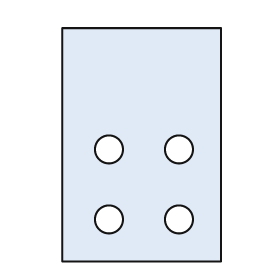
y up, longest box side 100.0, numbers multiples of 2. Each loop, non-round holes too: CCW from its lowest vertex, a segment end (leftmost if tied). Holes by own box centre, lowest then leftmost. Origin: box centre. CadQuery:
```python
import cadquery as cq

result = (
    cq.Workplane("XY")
    .moveTo(-34.0, -50.0)
    .lineTo(34.0, -50.0)
    .lineTo(34.0, 50.0)
    .lineTo(-34.0, 50.0)
    .close()
    .moveTo(-14.0, -32.0)
    .circle(6.0)
    .moveTo(16.0, -32.0)
    .circle(6.0)
    .moveTo(-14.0, -2.0)
    .circle(6.0)
    .moveTo(16.0, -2.0)
    .circle(6.0)
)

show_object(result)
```